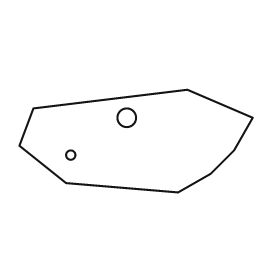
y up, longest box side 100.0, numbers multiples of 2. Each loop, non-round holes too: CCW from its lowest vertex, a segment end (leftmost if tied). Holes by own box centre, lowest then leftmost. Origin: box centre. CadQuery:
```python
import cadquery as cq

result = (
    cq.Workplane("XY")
    .moveTo(18.0, -22.0)
    .lineTo(32.0, -14.0)
    .lineTo(42.0, -4.0)
    .lineTo(50.0, 10.0)
    .lineTo(22.0, 22.0)
    .lineTo(-44.0, 14.0)
    .lineTo(-50.0, -2.0)
    .lineTo(-30.0, -18.0)
    .close()
    .moveTo(-28.0, -6.0)
    .circle(2.0)
    .moveTo(-4.0, 10.0)
    .circle(4.0)
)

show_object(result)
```